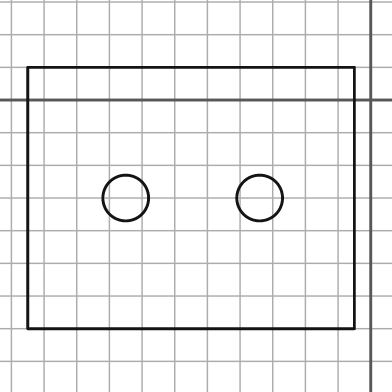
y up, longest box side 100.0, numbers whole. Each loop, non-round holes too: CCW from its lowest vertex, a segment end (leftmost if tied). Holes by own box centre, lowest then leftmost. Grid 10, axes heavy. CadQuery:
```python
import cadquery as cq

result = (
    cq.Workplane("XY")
    .moveTo(-105.0, -70.0)
    .lineTo(-5.0, -70.0)
    .lineTo(-5.0, 10.0)
    .lineTo(-105.0, 10.0)
    .close()
    .moveTo(-75.0, -30.0)
    .circle(7.0)
    .moveTo(-34.0, -30.0)
    .circle(7.0)
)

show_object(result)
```